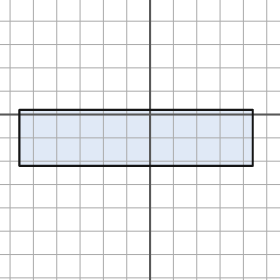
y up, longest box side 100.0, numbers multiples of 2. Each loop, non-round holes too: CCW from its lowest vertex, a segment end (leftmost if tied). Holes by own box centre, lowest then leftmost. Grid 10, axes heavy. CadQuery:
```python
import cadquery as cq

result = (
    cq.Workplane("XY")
    .moveTo(-56.0, -22.0)
    .lineTo(44.0, -22.0)
    .lineTo(44.0, 2.0)
    .lineTo(-56.0, 2.0)
    .close()
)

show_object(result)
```